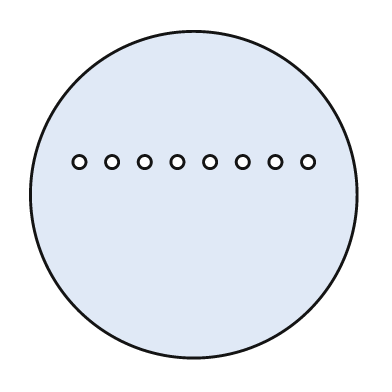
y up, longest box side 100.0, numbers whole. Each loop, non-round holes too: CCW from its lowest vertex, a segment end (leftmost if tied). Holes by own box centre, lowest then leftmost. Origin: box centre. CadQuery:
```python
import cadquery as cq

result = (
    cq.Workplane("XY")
    .moveTo(0.0, 0.0)
    .circle(50.0)
    .moveTo(-35.0, 10.0)
    .circle(2.0)
    .moveTo(-25.0, 10.0)
    .circle(2.0)
    .moveTo(-15.0, 10.0)
    .circle(2.0)
    .moveTo(-5.0, 10.0)
    .circle(2.0)
    .moveTo(5.0, 10.0)
    .circle(2.0)
    .moveTo(15.0, 10.0)
    .circle(2.0)
    .moveTo(25.0, 10.0)
    .circle(2.0)
    .moveTo(35.0, 10.0)
    .circle(2.0)
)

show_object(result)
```